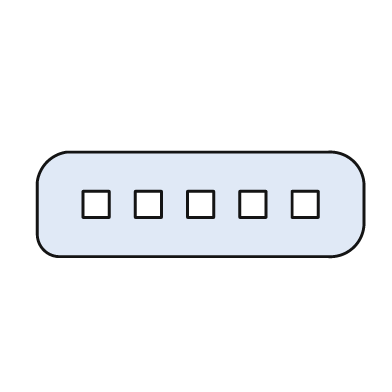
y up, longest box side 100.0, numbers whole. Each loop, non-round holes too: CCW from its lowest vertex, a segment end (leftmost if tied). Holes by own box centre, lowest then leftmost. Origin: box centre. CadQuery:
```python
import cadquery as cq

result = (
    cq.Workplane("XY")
    .moveTo(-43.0, -16.0)
    .lineTo(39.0, -16.0)
    .threePointArc((47.0, -13.0), (50.0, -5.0))
    .lineTo(50.0, 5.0)
    .threePointArc((47.0, 13.0), (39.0, 16.0))
    .lineTo(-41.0, 16.0)
    .threePointArc((-47.0, 13.0), (-50.0, 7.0))
    .lineTo(-50.0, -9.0)
    .threePointArc((-48.0, -14.0), (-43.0, -16.0))
    .close()
    .moveTo(-36.0, -4.0)
    .lineTo(-28.0, -4.0)
    .lineTo(-28.0, 4.0)
    .lineTo(-36.0, 4.0)
    .close()
    .moveTo(-20.0, -4.0)
    .lineTo(-12.0, -4.0)
    .lineTo(-12.0, 4.0)
    .lineTo(-20.0, 4.0)
    .close()
    .moveTo(-4.0, -4.0)
    .lineTo(4.0, -4.0)
    .lineTo(4.0, 4.0)
    .lineTo(-4.0, 4.0)
    .close()
    .moveTo(12.0, -4.0)
    .lineTo(20.0, -4.0)
    .lineTo(20.0, 4.0)
    .lineTo(12.0, 4.0)
    .close()
    .moveTo(28.0, -4.0)
    .lineTo(36.0, -4.0)
    .lineTo(36.0, 4.0)
    .lineTo(28.0, 4.0)
    .close()
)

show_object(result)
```